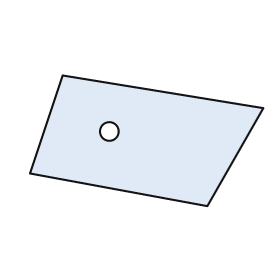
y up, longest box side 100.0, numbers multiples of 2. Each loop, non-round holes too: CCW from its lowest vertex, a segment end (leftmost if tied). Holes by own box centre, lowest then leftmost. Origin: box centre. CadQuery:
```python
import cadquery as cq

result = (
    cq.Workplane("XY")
    .moveTo(26.0, -28.0)
    .lineTo(50.0, 14.0)
    .lineTo(-36.0, 28.0)
    .lineTo(-50.0, -14.0)
    .close()
    .moveTo(-16.0, 4.0)
    .circle(4.0)
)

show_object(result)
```